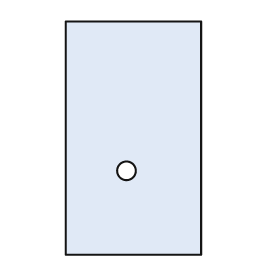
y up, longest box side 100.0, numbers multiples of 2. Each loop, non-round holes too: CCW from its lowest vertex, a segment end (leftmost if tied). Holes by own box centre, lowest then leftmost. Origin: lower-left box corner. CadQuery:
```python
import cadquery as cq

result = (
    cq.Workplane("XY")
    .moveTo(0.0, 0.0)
    .lineTo(58.0, 0.0)
    .lineTo(58.0, 100.0)
    .lineTo(0.0, 100.0)
    .close()
    .moveTo(26.0, 36.0)
    .circle(4.0)
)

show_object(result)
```